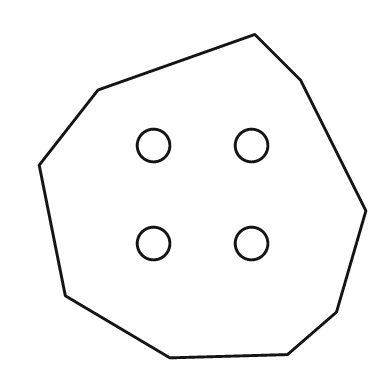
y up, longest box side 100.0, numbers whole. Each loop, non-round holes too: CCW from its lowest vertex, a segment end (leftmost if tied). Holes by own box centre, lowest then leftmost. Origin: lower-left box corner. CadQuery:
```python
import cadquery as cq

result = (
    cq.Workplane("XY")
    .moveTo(40.0, 0.0)
    .lineTo(76.0, 1.0)
    .lineTo(91.0, 14.0)
    .lineTo(100.0, 45.0)
    .lineTo(80.0, 85.0)
    .lineTo(66.0, 99.0)
    .lineTo(18.0, 82.0)
    .lineTo(0.0, 59.0)
    .lineTo(8.0, 19.0)
    .close()
    .moveTo(35.0, 35.0)
    .circle(5.0)
    .moveTo(65.0, 35.0)
    .circle(5.0)
    .moveTo(35.0, 65.0)
    .circle(5.0)
    .moveTo(65.0, 65.0)
    .circle(5.0)
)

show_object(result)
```